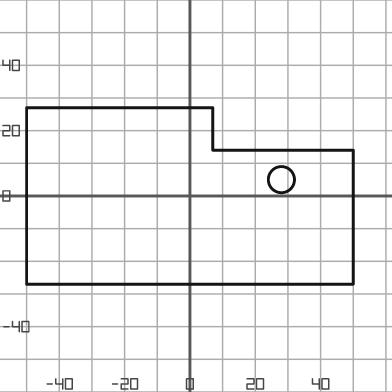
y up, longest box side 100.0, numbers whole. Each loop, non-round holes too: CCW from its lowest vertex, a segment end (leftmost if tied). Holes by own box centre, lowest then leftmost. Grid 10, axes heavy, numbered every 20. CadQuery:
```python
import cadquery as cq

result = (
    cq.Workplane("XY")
    .moveTo(-50.0, -27.0)
    .lineTo(50.0, -27.0)
    .lineTo(50.0, 14.0)
    .lineTo(7.0, 14.0)
    .lineTo(7.0, 27.0)
    .lineTo(-50.0, 27.0)
    .close()
    .moveTo(28.0, 5.0)
    .circle(4.0)
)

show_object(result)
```